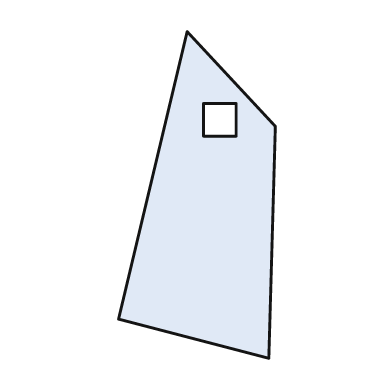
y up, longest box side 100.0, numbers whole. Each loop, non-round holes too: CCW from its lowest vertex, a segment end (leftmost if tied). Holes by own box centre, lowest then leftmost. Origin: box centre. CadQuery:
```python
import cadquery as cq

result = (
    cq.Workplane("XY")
    .moveTo(22.0, -50.0)
    .lineTo(24.0, 21.0)
    .lineTo(-3.0, 50.0)
    .lineTo(-24.0, -38.0)
    .close()
    .moveTo(2.0, 18.0)
    .lineTo(12.0, 18.0)
    .lineTo(12.0, 28.0)
    .lineTo(2.0, 28.0)
    .close()
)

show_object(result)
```